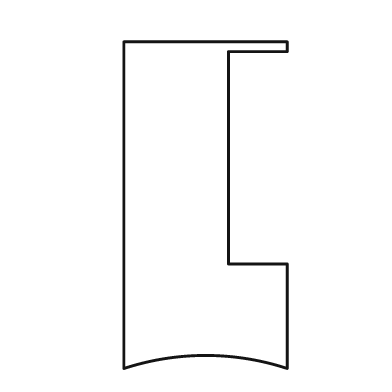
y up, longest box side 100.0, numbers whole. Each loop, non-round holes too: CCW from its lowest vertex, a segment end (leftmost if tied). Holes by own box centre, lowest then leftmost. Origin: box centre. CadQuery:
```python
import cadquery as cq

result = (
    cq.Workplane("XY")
    .moveTo(-25.0, -50.0)
    .threePointArc((0.0, -46.0), (25.0, -50.0))
    .lineTo(25.0, -18.0)
    .lineTo(7.0, -18.0)
    .lineTo(7.0, 47.0)
    .lineTo(25.0, 47.0)
    .lineTo(25.0, 50.0)
    .lineTo(-25.0, 50.0)
    .close()
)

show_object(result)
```